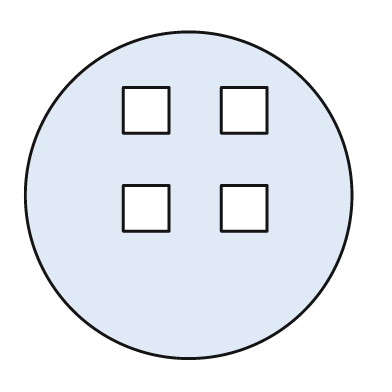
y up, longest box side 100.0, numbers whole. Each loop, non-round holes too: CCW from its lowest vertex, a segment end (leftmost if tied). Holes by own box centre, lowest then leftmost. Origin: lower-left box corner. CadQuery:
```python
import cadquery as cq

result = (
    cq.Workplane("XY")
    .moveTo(50.0, 50.0)
    .circle(50.0)
    .moveTo(30.0, 39.0)
    .lineTo(44.0, 39.0)
    .lineTo(44.0, 53.0)
    .lineTo(30.0, 53.0)
    .close()
    .moveTo(60.0, 39.0)
    .lineTo(74.0, 39.0)
    .lineTo(74.0, 53.0)
    .lineTo(60.0, 53.0)
    .close()
    .moveTo(30.0, 69.0)
    .lineTo(44.0, 69.0)
    .lineTo(44.0, 83.0)
    .lineTo(30.0, 83.0)
    .close()
    .moveTo(60.0, 69.0)
    .lineTo(74.0, 69.0)
    .lineTo(74.0, 83.0)
    .lineTo(60.0, 83.0)
    .close()
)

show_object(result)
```